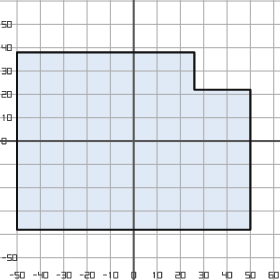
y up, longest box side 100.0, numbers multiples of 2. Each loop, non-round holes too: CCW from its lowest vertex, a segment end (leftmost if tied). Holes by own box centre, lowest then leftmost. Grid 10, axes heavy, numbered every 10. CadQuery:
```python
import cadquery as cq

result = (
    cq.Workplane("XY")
    .moveTo(-50.0, -38.0)
    .lineTo(50.0, -38.0)
    .lineTo(50.0, 22.0)
    .lineTo(26.0, 22.0)
    .lineTo(26.0, 38.0)
    .lineTo(-50.0, 38.0)
    .close()
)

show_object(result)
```